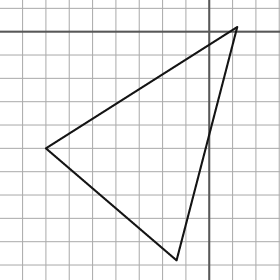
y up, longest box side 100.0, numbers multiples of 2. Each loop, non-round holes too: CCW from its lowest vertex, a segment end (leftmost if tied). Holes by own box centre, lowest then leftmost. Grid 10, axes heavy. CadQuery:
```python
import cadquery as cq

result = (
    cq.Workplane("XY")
    .moveTo(-14.0, -98.0)
    .lineTo(12.0, 2.0)
    .lineTo(-70.0, -50.0)
    .close()
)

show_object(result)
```